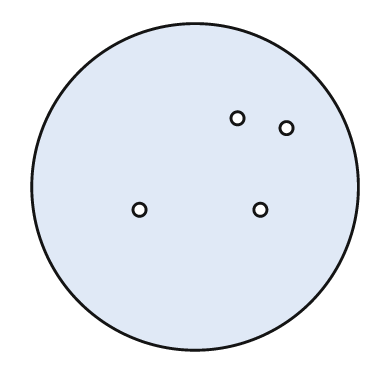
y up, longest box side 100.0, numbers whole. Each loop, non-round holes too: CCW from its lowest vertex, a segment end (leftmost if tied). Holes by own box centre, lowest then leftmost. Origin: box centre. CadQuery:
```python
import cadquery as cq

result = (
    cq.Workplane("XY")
    .moveTo(0.0, 0.0)
    .circle(50.0)
    .moveTo(-17.0, -7.0)
    .circle(2.0)
    .moveTo(20.0, -7.0)
    .circle(2.0)
    .moveTo(28.0, 18.0)
    .circle(2.0)
    .moveTo(13.0, 21.0)
    .circle(2.0)
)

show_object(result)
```